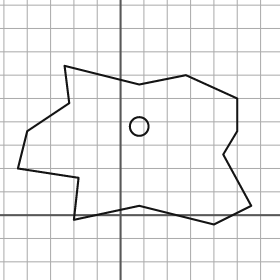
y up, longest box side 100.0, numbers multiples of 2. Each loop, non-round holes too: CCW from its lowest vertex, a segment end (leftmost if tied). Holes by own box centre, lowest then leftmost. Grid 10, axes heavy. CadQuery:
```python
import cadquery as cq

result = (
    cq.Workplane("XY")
    .moveTo(40.0, -4.0)
    .lineTo(56.0, 4.0)
    .lineTo(44.0, 26.0)
    .lineTo(50.0, 36.0)
    .lineTo(50.0, 50.0)
    .lineTo(28.0, 60.0)
    .lineTo(8.0, 56.0)
    .lineTo(-24.0, 64.0)
    .lineTo(-22.0, 48.0)
    .lineTo(-40.0, 36.0)
    .lineTo(-44.0, 20.0)
    .lineTo(-18.0, 16.0)
    .lineTo(-20.0, -2.0)
    .lineTo(8.0, 4.0)
    .close()
    .moveTo(8.0, 38.0)
    .circle(4.0)
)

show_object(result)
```